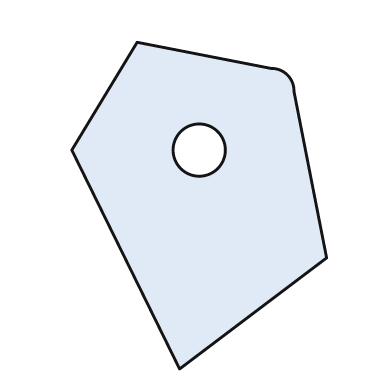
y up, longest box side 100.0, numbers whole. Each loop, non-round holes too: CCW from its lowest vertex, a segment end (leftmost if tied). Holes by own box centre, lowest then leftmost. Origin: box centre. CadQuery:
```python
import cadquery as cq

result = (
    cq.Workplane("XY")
    .moveTo(-6.0, -50.0)
    .lineTo(39.0, -16.0)
    .lineTo(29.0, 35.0)
    .threePointArc((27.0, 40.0), (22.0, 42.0))
    .lineTo(-19.0, 50.0)
    .lineTo(-39.0, 17.0)
    .close()
    .moveTo(0.0, 17.0)
    .circle(8.0)
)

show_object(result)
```